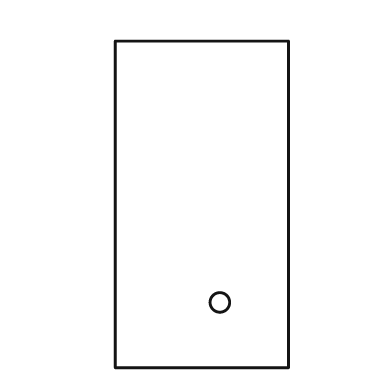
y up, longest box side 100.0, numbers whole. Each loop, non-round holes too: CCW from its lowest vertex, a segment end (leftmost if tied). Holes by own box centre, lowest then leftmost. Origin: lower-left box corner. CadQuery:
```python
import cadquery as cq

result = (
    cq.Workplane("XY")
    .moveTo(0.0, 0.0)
    .lineTo(53.0, 0.0)
    .lineTo(53.0, 100.0)
    .lineTo(0.0, 100.0)
    .close()
    .moveTo(32.0, 20.0)
    .circle(3.0)
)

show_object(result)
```